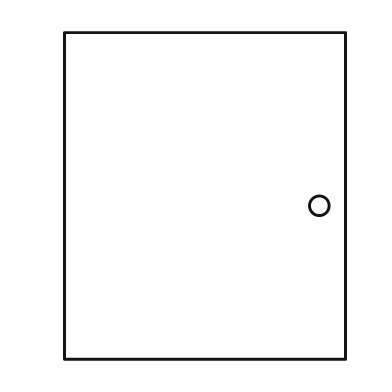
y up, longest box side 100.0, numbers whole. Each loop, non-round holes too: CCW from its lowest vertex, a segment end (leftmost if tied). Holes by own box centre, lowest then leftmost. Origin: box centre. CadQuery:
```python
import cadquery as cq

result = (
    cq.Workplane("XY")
    .moveTo(-43.0, -50.0)
    .lineTo(43.0, -50.0)
    .lineTo(43.0, 50.0)
    .lineTo(-43.0, 50.0)
    .close()
    .moveTo(35.0, -3.0)
    .circle(3.0)
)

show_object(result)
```